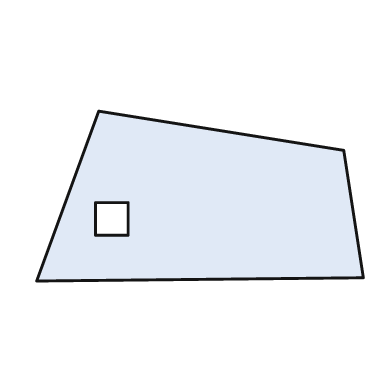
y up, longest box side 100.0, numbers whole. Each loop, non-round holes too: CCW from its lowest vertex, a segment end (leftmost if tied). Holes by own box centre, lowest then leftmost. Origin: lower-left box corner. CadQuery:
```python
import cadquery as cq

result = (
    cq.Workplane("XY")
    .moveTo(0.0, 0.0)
    .lineTo(100.0, 1.0)
    .lineTo(94.0, 40.0)
    .lineTo(19.0, 52.0)
    .close()
    .moveTo(18.0, 14.0)
    .lineTo(28.0, 14.0)
    .lineTo(28.0, 24.0)
    .lineTo(18.0, 24.0)
    .close()
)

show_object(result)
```